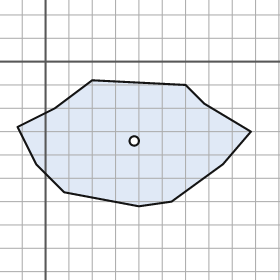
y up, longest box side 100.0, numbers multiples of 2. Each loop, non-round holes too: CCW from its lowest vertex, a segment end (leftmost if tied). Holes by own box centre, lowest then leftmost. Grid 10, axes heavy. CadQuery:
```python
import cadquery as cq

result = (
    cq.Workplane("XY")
    .moveTo(40.0, -62.0)
    .lineTo(54.0, -60.0)
    .lineTo(76.0, -44.0)
    .lineTo(88.0, -30.0)
    .lineTo(68.0, -18.0)
    .lineTo(60.0, -10.0)
    .lineTo(20.0, -8.0)
    .lineTo(4.0, -20.0)
    .lineTo(-12.0, -28.0)
    .lineTo(-4.0, -44.0)
    .lineTo(8.0, -56.0)
    .close()
    .moveTo(38.0, -34.0)
    .circle(2.0)
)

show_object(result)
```